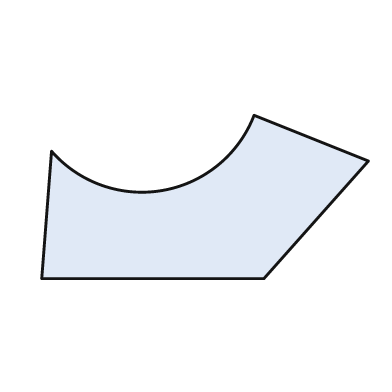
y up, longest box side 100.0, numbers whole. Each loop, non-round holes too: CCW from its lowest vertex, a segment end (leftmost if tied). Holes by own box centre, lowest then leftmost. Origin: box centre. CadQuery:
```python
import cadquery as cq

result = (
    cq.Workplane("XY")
    .moveTo(-50.0, -25.0)
    .lineTo(18.0, -25.0)
    .lineTo(50.0, 11.0)
    .lineTo(15.0, 25.0)
    .threePointArc((-13.0, 2.0), (-47.0, 14.0))
    .close()
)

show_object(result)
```